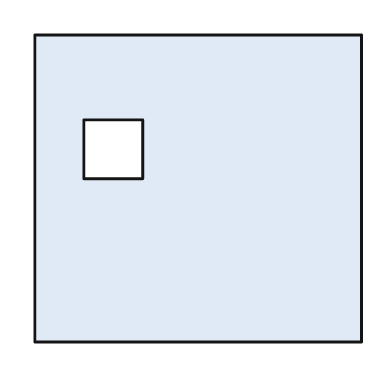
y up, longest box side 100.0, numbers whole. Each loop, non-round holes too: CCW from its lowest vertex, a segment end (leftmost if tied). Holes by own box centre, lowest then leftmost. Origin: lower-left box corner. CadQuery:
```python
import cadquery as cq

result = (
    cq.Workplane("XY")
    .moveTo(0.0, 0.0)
    .lineTo(100.0, 0.0)
    .lineTo(100.0, 94.0)
    .lineTo(0.0, 94.0)
    .close()
    .moveTo(15.0, 50.0)
    .lineTo(33.0, 50.0)
    .lineTo(33.0, 68.0)
    .lineTo(15.0, 68.0)
    .close()
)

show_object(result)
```